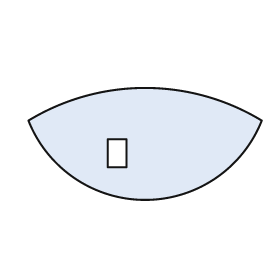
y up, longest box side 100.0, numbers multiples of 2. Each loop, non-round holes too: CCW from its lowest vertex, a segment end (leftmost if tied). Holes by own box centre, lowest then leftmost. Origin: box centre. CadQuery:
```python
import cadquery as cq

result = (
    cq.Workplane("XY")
    .moveTo(-50.0, 10.0)
    .threePointArc((0.0, -24.0), (50.0, 10.0))
    .threePointArc((0.0, 24.0), (-50.0, 10.0))
    .close()
    .moveTo(-16.0, -10.0)
    .lineTo(-8.0, -10.0)
    .lineTo(-8.0, 2.0)
    .lineTo(-16.0, 2.0)
    .close()
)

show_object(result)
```